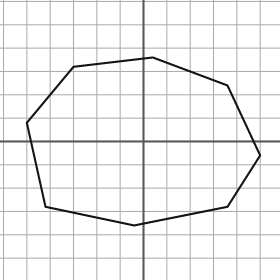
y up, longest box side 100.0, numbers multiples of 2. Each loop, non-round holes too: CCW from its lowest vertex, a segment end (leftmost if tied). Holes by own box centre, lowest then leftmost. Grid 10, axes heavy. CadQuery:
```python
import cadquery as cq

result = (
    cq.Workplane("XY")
    .moveTo(-4.0, -36.0)
    .lineTo(36.0, -28.0)
    .lineTo(50.0, -6.0)
    .lineTo(36.0, 24.0)
    .lineTo(4.0, 36.0)
    .lineTo(-30.0, 32.0)
    .lineTo(-50.0, 8.0)
    .lineTo(-42.0, -28.0)
    .close()
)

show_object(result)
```